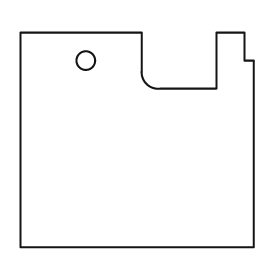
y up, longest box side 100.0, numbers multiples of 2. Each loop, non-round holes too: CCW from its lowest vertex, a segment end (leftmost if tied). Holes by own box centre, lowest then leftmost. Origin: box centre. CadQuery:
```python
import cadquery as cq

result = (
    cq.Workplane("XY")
    .moveTo(-50.0, -46.0)
    .lineTo(50.0, -46.0)
    .lineTo(50.0, 34.0)
    .lineTo(46.0, 34.0)
    .lineTo(46.0, 46.0)
    .lineTo(34.0, 46.0)
    .lineTo(34.0, 22.0)
    .lineTo(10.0, 22.0)
    .threePointArc((4.0, 24.0), (2.0, 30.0))
    .lineTo(2.0, 46.0)
    .lineTo(-50.0, 46.0)
    .close()
    .moveTo(-22.0, 34.0)
    .circle(4.0)
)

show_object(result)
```